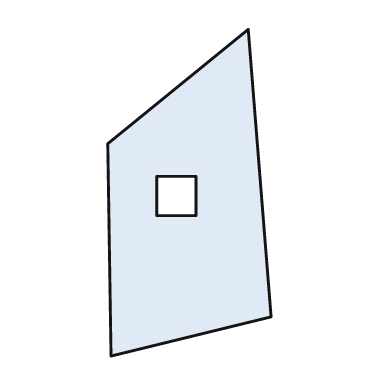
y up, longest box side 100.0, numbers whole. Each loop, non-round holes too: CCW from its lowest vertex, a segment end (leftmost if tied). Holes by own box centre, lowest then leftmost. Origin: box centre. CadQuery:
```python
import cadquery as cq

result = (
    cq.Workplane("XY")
    .moveTo(-24.0, -50.0)
    .lineTo(25.0, -38.0)
    .lineTo(18.0, 50.0)
    .lineTo(-25.0, 15.0)
    .close()
    .moveTo(-10.0, -7.0)
    .lineTo(2.0, -7.0)
    .lineTo(2.0, 5.0)
    .lineTo(-10.0, 5.0)
    .close()
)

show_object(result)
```